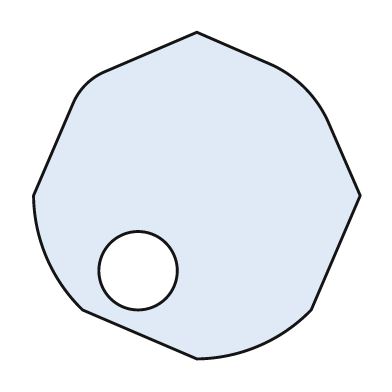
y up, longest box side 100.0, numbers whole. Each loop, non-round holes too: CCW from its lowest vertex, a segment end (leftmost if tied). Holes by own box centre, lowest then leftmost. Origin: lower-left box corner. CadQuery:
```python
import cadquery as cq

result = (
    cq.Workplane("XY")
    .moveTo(50.0, 0.0)
    .threePointArc((69.0, 4.0), (85.0, 15.0))
    .lineTo(100.0, 50.0)
    .lineTo(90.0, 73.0)
    .threePointArc((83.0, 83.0), (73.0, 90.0))
    .lineTo(50.0, 100.0)
    .lineTo(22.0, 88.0)
    .threePointArc((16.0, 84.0), (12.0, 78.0))
    .lineTo(0.0, 50.0)
    .threePointArc((4.0, 31.0), (15.0, 15.0))
    .close()
    .moveTo(32.0, 27.0)
    .circle(12.0)
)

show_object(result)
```